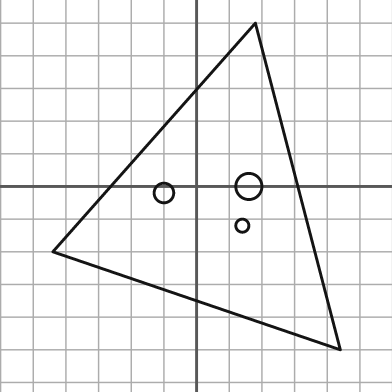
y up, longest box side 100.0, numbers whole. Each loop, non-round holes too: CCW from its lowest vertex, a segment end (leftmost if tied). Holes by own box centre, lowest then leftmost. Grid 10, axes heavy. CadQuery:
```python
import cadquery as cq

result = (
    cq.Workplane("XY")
    .moveTo(44.0, -50.0)
    .lineTo(18.0, 50.0)
    .lineTo(-44.0, -20.0)
    .close()
    .moveTo(14.0, -12.0)
    .circle(2.0)
    .moveTo(-10.0, -2.0)
    .circle(3.0)
    .moveTo(16.0, 0.0)
    .circle(4.0)
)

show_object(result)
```